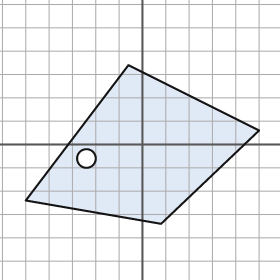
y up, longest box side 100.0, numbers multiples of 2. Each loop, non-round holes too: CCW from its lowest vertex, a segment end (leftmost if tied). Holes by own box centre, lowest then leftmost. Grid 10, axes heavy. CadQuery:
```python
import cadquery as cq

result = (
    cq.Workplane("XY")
    .moveTo(8.0, -34.0)
    .lineTo(50.0, 6.0)
    .lineTo(-6.0, 34.0)
    .lineTo(-50.0, -24.0)
    .close()
    .moveTo(-24.0, -6.0)
    .circle(4.0)
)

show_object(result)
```